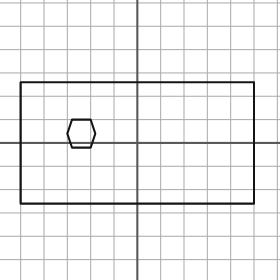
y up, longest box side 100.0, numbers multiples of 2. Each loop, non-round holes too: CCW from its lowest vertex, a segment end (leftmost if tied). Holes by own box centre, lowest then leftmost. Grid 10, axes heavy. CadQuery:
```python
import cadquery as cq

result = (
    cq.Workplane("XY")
    .moveTo(-50.0, -26.0)
    .lineTo(50.0, -26.0)
    .lineTo(50.0, 26.0)
    .lineTo(-50.0, 26.0)
    .close()
    .moveTo(-28.0, -2.0)
    .lineTo(-20.0, -2.0)
    .lineTo(-18.0, 4.0)
    .lineTo(-20.0, 10.0)
    .lineTo(-28.0, 10.0)
    .lineTo(-30.0, 4.0)
    .close()
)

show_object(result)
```